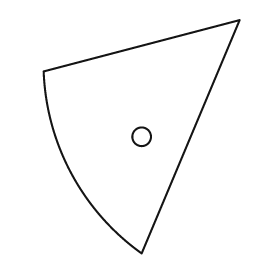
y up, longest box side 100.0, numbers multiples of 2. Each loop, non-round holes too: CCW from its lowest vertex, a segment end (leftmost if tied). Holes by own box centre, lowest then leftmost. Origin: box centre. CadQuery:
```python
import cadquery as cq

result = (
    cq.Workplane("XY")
    .moveTo(0.0, -50.0)
    .lineTo(42.0, 50.0)
    .lineTo(-42.0, 28.0)
    .threePointArc((-30.0, -16.0), (0.0, -50.0))
    .close()
    .moveTo(0.0, 0.0)
    .circle(4.0)
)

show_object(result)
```